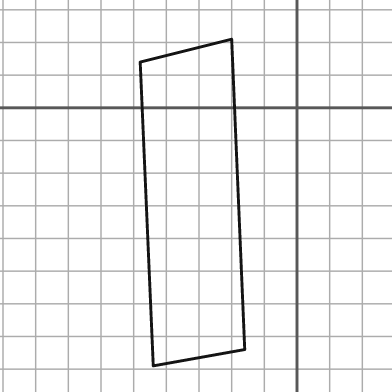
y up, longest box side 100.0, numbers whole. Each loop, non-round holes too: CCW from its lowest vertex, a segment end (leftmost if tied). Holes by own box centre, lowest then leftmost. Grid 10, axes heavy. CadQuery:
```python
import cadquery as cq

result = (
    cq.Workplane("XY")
    .moveTo(-44.0, -79.0)
    .lineTo(-16.0, -74.0)
    .lineTo(-20.0, 21.0)
    .lineTo(-48.0, 14.0)
    .close()
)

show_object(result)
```